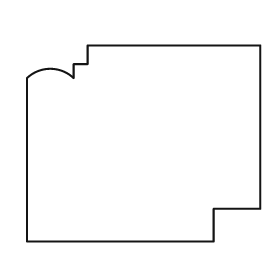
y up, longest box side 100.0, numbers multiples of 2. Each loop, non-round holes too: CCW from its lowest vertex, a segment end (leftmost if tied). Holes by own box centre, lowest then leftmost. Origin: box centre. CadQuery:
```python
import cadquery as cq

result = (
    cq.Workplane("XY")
    .moveTo(-50.0, -42.0)
    .lineTo(30.0, -42.0)
    .lineTo(30.0, -28.0)
    .lineTo(50.0, -28.0)
    .lineTo(50.0, 42.0)
    .lineTo(-24.0, 42.0)
    .lineTo(-24.0, 34.0)
    .lineTo(-30.0, 34.0)
    .lineTo(-30.0, 28.0)
    .threePointArc((-40.0, 32.0), (-50.0, 28.0))
    .close()
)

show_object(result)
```